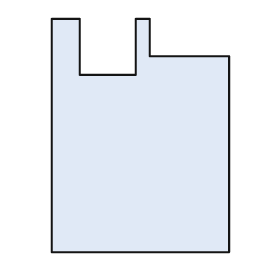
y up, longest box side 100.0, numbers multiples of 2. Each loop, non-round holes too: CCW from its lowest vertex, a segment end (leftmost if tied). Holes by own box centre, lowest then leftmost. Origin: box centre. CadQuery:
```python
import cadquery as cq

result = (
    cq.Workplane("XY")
    .moveTo(-38.0, -50.0)
    .lineTo(38.0, -50.0)
    .lineTo(38.0, 34.0)
    .lineTo(4.0, 34.0)
    .lineTo(4.0, 50.0)
    .lineTo(-2.0, 50.0)
    .lineTo(-2.0, 26.0)
    .lineTo(-26.0, 26.0)
    .lineTo(-26.0, 50.0)
    .lineTo(-38.0, 50.0)
    .close()
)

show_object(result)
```